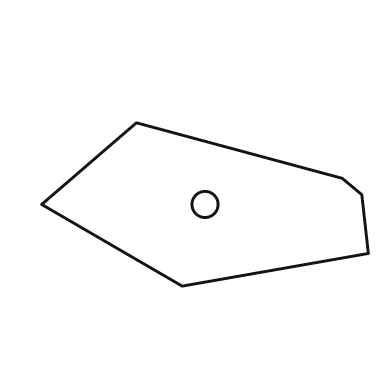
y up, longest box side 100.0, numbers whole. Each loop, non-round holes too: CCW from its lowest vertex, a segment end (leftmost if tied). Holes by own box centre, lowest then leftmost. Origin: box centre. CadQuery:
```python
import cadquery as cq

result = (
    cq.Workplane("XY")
    .moveTo(-7.0, -25.0)
    .lineTo(50.0, -15.0)
    .lineTo(48.0, 3.0)
    .lineTo(42.0, 8.0)
    .lineTo(-21.0, 25.0)
    .lineTo(-50.0, 0.0)
    .close()
    .moveTo(0.0, 0.0)
    .circle(4.0)
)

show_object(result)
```